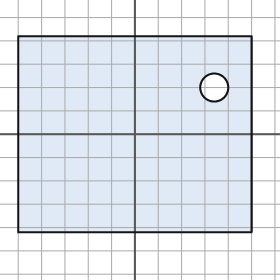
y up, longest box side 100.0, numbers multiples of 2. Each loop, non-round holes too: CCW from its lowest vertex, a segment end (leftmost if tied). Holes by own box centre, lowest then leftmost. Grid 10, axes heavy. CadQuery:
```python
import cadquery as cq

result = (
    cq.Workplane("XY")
    .moveTo(-50.0, -42.0)
    .lineTo(50.0, -42.0)
    .lineTo(50.0, 42.0)
    .lineTo(-50.0, 42.0)
    .close()
    .moveTo(34.0, 20.0)
    .circle(6.0)
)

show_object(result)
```